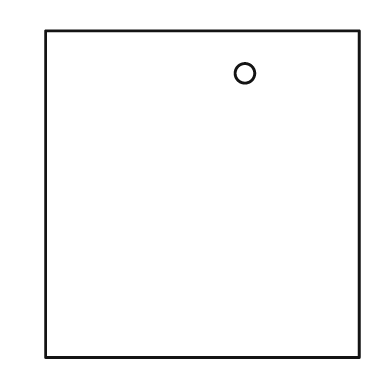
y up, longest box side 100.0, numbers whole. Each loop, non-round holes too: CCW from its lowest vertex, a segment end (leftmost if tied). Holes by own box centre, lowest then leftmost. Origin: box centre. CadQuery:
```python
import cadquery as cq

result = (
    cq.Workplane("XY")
    .moveTo(-48.0, -50.0)
    .lineTo(48.0, -50.0)
    .lineTo(48.0, 50.0)
    .lineTo(-48.0, 50.0)
    .close()
    .moveTo(13.0, 37.0)
    .circle(3.0)
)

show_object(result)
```